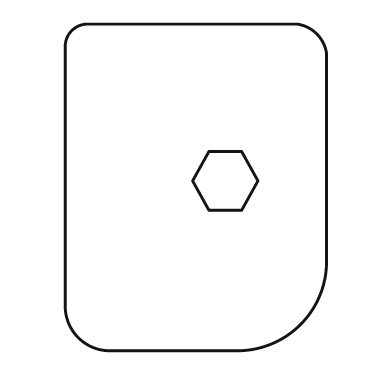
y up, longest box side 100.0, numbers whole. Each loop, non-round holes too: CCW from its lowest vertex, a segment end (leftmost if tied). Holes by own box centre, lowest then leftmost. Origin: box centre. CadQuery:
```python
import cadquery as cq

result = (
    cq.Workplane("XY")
    .moveTo(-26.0, -50.0)
    .lineTo(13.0, -50.0)
    .threePointArc((32.0, -42.0), (40.0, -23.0))
    .lineTo(40.0, 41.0)
    .threePointArc((37.0, 47.0), (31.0, 50.0))
    .lineTo(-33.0, 50.0)
    .threePointArc((-38.0, 48.0), (-40.0, 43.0))
    .lineTo(-40.0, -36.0)
    .threePointArc((-36.0, -46.0), (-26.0, -50.0))
    .close()
    .moveTo(4.0, -7.0)
    .lineTo(14.0, -7.0)
    .lineTo(19.0, 2.0)
    .lineTo(14.0, 11.0)
    .lineTo(4.0, 11.0)
    .lineTo(-1.0, 2.0)
    .close()
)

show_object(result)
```